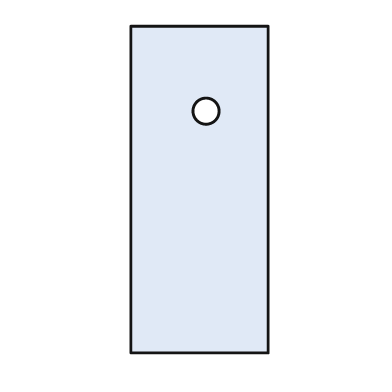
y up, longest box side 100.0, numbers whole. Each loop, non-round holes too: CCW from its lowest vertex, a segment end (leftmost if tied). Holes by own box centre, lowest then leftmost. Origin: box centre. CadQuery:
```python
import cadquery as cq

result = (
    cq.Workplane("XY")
    .moveTo(-21.0, -50.0)
    .lineTo(21.0, -50.0)
    .lineTo(21.0, 50.0)
    .lineTo(-21.0, 50.0)
    .close()
    .moveTo(2.0, 24.0)
    .circle(4.0)
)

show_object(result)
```